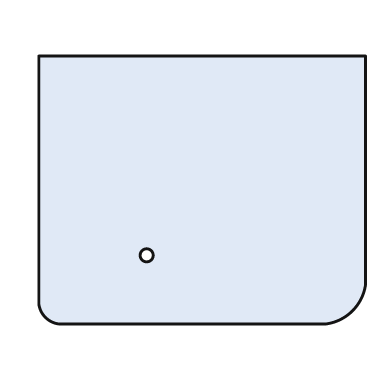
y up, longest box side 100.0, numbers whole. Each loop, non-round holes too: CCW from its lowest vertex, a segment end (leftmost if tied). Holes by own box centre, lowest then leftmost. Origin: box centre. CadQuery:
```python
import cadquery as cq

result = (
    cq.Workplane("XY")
    .moveTo(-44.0, -41.0)
    .lineTo(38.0, -41.0)
    .threePointArc((46.0, -37.0), (50.0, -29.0))
    .lineTo(50.0, 41.0)
    .lineTo(-50.0, 41.0)
    .lineTo(-50.0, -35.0)
    .threePointArc((-48.0, -39.0), (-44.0, -41.0))
    .close()
    .moveTo(-17.0, -20.0)
    .circle(2.0)
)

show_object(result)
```